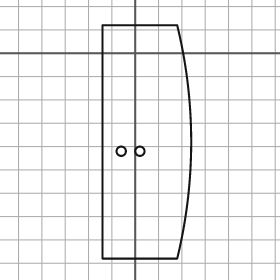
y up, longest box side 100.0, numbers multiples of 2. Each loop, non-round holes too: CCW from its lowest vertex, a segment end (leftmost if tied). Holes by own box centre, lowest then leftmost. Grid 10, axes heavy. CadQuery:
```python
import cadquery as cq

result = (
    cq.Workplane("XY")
    .moveTo(-14.0, -88.0)
    .lineTo(18.0, -88.0)
    .threePointArc((24.0, -38.0), (18.0, 12.0))
    .lineTo(-14.0, 12.0)
    .close()
    .moveTo(-6.0, -42.0)
    .circle(2.0)
    .moveTo(2.0, -42.0)
    .circle(2.0)
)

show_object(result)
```